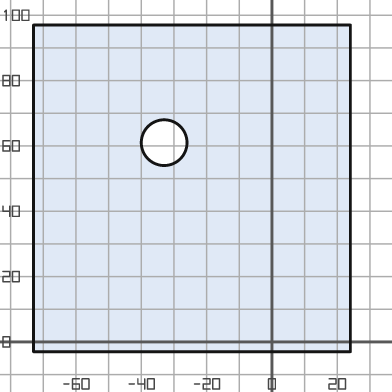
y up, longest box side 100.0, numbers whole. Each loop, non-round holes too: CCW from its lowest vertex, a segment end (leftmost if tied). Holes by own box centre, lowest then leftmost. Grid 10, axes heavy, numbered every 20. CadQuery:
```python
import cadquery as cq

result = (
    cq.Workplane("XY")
    .moveTo(-73.0, -3.0)
    .lineTo(24.0, -3.0)
    .lineTo(24.0, 97.0)
    .lineTo(-73.0, 97.0)
    .close()
    .moveTo(-33.0, 61.0)
    .circle(7.0)
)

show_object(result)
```